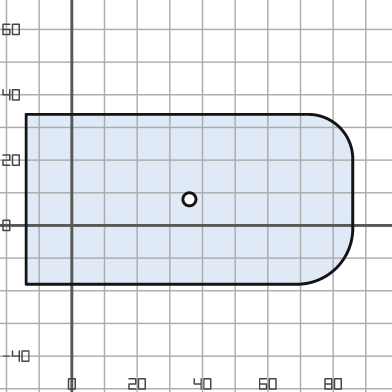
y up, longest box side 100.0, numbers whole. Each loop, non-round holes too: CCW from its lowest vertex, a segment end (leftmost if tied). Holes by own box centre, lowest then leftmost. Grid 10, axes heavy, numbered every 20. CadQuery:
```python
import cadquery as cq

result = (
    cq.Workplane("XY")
    .moveTo(-14.0, -18.0)
    .lineTo(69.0, -18.0)
    .threePointArc((81.0, -13.0), (86.0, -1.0))
    .lineTo(86.0, 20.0)
    .threePointArc((82.0, 30.0), (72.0, 34.0))
    .lineTo(-14.0, 34.0)
    .close()
    .moveTo(36.0, 8.0)
    .circle(2.0)
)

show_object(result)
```